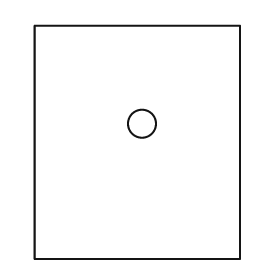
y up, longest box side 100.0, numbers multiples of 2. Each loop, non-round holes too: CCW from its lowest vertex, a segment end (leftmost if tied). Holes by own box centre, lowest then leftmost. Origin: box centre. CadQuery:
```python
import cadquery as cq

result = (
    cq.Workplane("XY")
    .moveTo(-44.0, -50.0)
    .lineTo(44.0, -50.0)
    .lineTo(44.0, 50.0)
    .lineTo(-44.0, 50.0)
    .close()
    .moveTo(2.0, 8.0)
    .circle(6.0)
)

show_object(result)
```